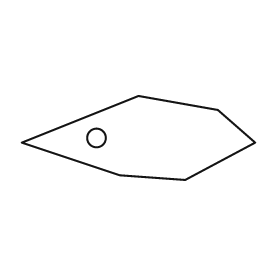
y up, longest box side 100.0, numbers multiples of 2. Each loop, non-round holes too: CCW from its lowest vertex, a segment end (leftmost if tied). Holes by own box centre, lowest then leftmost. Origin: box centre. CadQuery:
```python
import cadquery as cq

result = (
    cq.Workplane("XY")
    .moveTo(20.0, -18.0)
    .lineTo(50.0, -2.0)
    .lineTo(34.0, 12.0)
    .lineTo(0.0, 18.0)
    .lineTo(-50.0, -2.0)
    .lineTo(-8.0, -16.0)
    .close()
    .moveTo(-18.0, 0.0)
    .circle(4.0)
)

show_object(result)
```